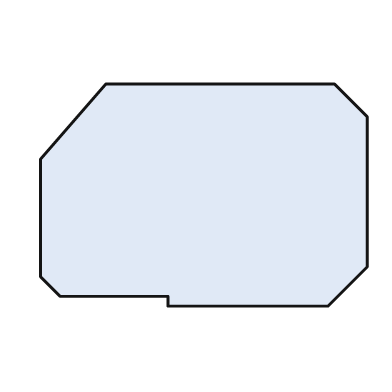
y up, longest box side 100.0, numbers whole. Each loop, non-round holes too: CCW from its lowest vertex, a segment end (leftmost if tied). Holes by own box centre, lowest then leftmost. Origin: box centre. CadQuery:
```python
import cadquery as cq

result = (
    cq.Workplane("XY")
    .moveTo(-11.0, -34.0)
    .lineTo(38.0, -34.0)
    .lineTo(50.0, -22.0)
    .lineTo(50.0, 24.0)
    .lineTo(40.0, 34.0)
    .lineTo(-30.0, 34.0)
    .lineTo(-50.0, 11.0)
    .lineTo(-50.0, -25.0)
    .lineTo(-44.0, -31.0)
    .lineTo(-11.0, -31.0)
    .close()
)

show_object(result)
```